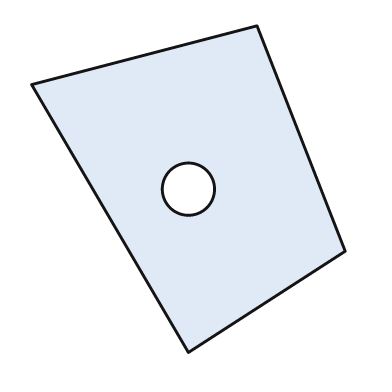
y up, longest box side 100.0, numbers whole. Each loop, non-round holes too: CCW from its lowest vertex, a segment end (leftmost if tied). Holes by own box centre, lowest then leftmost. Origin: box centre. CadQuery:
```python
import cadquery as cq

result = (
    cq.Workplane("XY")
    .moveTo(0.0, -50.0)
    .lineTo(48.0, -19.0)
    .lineTo(21.0, 50.0)
    .lineTo(-48.0, 32.0)
    .close()
    .moveTo(0.0, 0.0)
    .circle(8.0)
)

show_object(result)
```